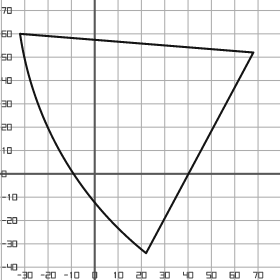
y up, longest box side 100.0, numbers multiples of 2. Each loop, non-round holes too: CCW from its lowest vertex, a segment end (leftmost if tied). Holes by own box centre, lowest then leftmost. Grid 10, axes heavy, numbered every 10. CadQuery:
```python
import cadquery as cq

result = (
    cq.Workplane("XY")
    .moveTo(22.0, -34.0)
    .lineTo(68.0, 52.0)
    .lineTo(-32.0, 60.0)
    .threePointArc((-14.0, 8.0), (22.0, -34.0))
    .close()
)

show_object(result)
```